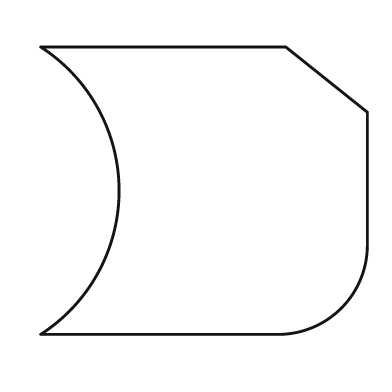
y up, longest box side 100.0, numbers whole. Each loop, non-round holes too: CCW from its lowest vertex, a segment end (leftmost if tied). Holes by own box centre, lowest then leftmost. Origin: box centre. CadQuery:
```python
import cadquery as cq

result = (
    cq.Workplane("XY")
    .moveTo(-50.0, -44.0)
    .lineTo(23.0, -44.0)
    .threePointArc((42.0, -36.0), (50.0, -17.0))
    .lineTo(50.0, 24.0)
    .lineTo(25.0, 44.0)
    .lineTo(-50.0, 44.0)
    .threePointArc((-26.0, 0.0), (-50.0, -44.0))
    .close()
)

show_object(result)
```